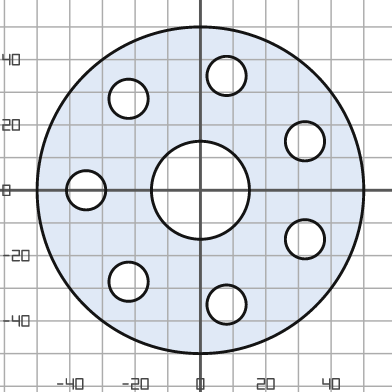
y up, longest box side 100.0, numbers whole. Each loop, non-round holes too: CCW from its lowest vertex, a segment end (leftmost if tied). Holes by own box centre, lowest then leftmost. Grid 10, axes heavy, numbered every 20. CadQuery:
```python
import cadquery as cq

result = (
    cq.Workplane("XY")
    .moveTo(0.0, 0.0)
    .circle(50.0)
    .moveTo(8.0, -35.0)
    .circle(6.0)
    .moveTo(-22.0, -28.0)
    .circle(6.0)
    .moveTo(32.0, -15.0)
    .circle(6.0)
    .moveTo(-35.0, 0.0)
    .circle(6.0)
    .moveTo(0.0, 0.0)
    .circle(15.0)
    .moveTo(32.0, 15.0)
    .circle(6.0)
    .moveTo(-22.0, 28.0)
    .circle(6.0)
    .moveTo(8.0, 35.0)
    .circle(6.0)
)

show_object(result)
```